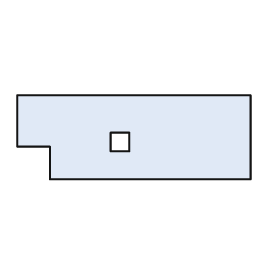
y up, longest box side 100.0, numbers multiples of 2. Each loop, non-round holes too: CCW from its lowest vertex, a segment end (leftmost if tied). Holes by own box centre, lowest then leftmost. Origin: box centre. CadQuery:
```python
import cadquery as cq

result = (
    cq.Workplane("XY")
    .moveTo(-36.0, -18.0)
    .lineTo(50.0, -18.0)
    .lineTo(50.0, 18.0)
    .lineTo(-50.0, 18.0)
    .lineTo(-50.0, -4.0)
    .lineTo(-36.0, -4.0)
    .close()
    .moveTo(-10.0, -6.0)
    .lineTo(-2.0, -6.0)
    .lineTo(-2.0, 2.0)
    .lineTo(-10.0, 2.0)
    .close()
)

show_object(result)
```